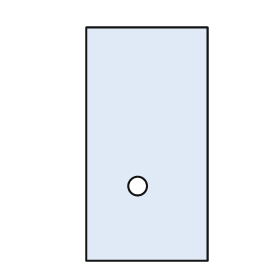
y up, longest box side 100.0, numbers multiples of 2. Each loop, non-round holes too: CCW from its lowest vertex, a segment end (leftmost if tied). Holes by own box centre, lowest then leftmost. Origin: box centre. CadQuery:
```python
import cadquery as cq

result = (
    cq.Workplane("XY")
    .moveTo(-26.0, -50.0)
    .lineTo(26.0, -50.0)
    .lineTo(26.0, 50.0)
    .lineTo(-26.0, 50.0)
    .close()
    .moveTo(-4.0, -18.0)
    .circle(4.0)
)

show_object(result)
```